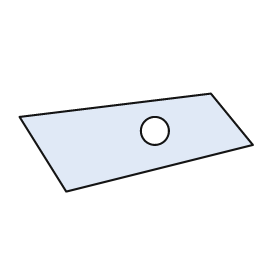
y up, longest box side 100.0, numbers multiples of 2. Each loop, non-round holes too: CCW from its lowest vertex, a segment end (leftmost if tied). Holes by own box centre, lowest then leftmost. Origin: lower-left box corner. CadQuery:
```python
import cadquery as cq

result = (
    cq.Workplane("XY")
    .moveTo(20.0, 0.0)
    .lineTo(100.0, 20.0)
    .lineTo(82.0, 42.0)
    .lineTo(0.0, 32.0)
    .close()
    .moveTo(58.0, 26.0)
    .circle(6.0)
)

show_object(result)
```